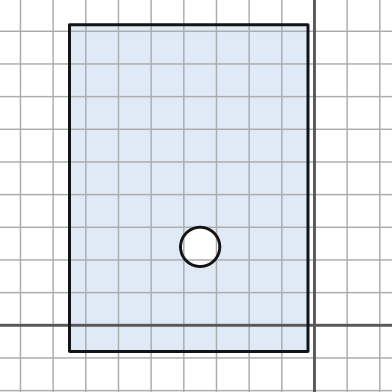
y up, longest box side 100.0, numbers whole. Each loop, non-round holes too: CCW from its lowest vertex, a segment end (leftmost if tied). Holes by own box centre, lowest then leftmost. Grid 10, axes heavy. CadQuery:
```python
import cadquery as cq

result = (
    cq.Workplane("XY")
    .moveTo(-75.0, -8.0)
    .lineTo(-2.0, -8.0)
    .lineTo(-2.0, 92.0)
    .lineTo(-75.0, 92.0)
    .close()
    .moveTo(-35.0, 24.0)
    .circle(6.0)
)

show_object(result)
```